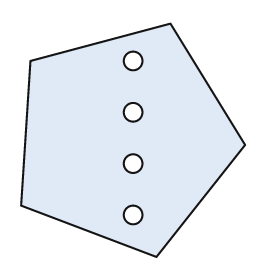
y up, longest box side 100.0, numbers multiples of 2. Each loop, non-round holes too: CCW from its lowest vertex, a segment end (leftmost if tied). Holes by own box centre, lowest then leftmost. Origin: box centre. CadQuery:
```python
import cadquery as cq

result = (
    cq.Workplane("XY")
    .moveTo(10.0, -50.0)
    .lineTo(48.0, -2.0)
    .lineTo(16.0, 50.0)
    .lineTo(-44.0, 34.0)
    .lineTo(-48.0, -28.0)
    .close()
    .moveTo(0.0, -32.0)
    .circle(4.0)
    .moveTo(0.0, -10.0)
    .circle(4.0)
    .moveTo(0.0, 12.0)
    .circle(4.0)
    .moveTo(0.0, 34.0)
    .circle(4.0)
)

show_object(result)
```